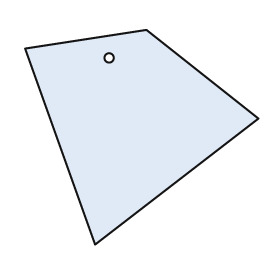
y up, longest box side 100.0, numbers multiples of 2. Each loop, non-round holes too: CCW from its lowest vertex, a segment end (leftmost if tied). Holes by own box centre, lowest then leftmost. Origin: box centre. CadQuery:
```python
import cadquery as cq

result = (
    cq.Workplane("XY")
    .moveTo(-20.0, -46.0)
    .lineTo(50.0, 8.0)
    .lineTo(2.0, 46.0)
    .lineTo(-50.0, 38.0)
    .close()
    .moveTo(-14.0, 34.0)
    .circle(2.0)
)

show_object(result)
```